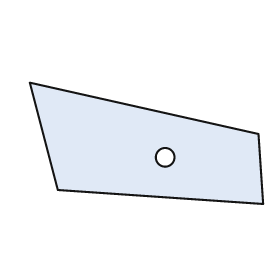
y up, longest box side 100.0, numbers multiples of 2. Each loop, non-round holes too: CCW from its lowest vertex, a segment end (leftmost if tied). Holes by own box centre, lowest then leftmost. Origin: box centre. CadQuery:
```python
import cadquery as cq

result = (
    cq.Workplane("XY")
    .moveTo(50.0, -26.0)
    .lineTo(48.0, 4.0)
    .lineTo(-50.0, 26.0)
    .lineTo(-38.0, -20.0)
    .close()
    .moveTo(8.0, -6.0)
    .circle(4.0)
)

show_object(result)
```